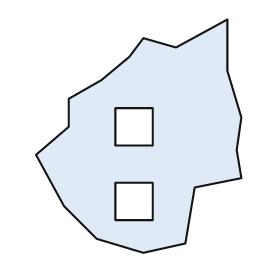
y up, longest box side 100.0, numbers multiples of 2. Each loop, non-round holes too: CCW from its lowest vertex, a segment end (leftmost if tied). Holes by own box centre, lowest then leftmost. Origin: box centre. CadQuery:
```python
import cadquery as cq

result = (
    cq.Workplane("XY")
    .moveTo(2.0, -50.0)
    .lineTo(20.0, -46.0)
    .lineTo(24.0, -22.0)
    .lineTo(44.0, -18.0)
    .lineTo(42.0, -6.0)
    .lineTo(44.0, 8.0)
    .lineTo(38.0, 28.0)
    .lineTo(38.0, 50.0)
    .lineTo(16.0, 38.0)
    .lineTo(2.0, 42.0)
    .lineTo(-4.0, 34.0)
    .lineTo(-16.0, 24.0)
    .lineTo(-30.0, 16.0)
    .lineTo(-30.0, 4.0)
    .lineTo(-44.0, -8.0)
    .lineTo(-32.0, -30.0)
    .lineTo(-18.0, -44.0)
    .close()
    .moveTo(-10.0, -36.0)
    .lineTo(6.0, -36.0)
    .lineTo(6.0, -20.0)
    .lineTo(-10.0, -20.0)
    .close()
    .moveTo(-10.0, -4.0)
    .lineTo(6.0, -4.0)
    .lineTo(6.0, 12.0)
    .lineTo(-10.0, 12.0)
    .close()
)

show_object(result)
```